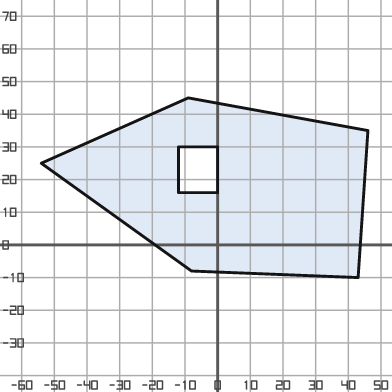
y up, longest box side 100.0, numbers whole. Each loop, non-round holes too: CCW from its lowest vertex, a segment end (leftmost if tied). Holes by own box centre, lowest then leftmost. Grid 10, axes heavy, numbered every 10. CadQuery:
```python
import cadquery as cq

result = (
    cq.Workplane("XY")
    .moveTo(43.0, -10.0)
    .lineTo(46.0, 35.0)
    .lineTo(-9.0, 45.0)
    .lineTo(-54.0, 25.0)
    .lineTo(-8.0, -8.0)
    .close()
    .moveTo(-12.0, 16.0)
    .lineTo(0.0, 16.0)
    .lineTo(0.0, 30.0)
    .lineTo(-12.0, 30.0)
    .close()
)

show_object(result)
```